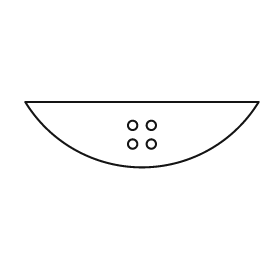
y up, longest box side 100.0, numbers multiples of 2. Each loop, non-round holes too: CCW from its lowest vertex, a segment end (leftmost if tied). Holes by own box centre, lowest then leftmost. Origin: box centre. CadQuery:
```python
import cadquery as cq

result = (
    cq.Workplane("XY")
    .moveTo(-50.0, 14.0)
    .threePointArc((0.0, -14.0), (50.0, 14.0))
    .close()
    .moveTo(-4.0, -4.0)
    .circle(2.0)
    .moveTo(4.0, -4.0)
    .circle(2.0)
    .moveTo(-4.0, 4.0)
    .circle(2.0)
    .moveTo(4.0, 4.0)
    .circle(2.0)
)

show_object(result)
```